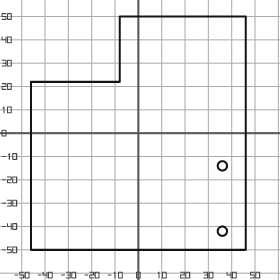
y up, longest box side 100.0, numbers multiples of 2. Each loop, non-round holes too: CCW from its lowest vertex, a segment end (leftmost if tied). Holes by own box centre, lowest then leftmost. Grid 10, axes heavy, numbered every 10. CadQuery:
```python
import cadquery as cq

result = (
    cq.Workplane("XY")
    .moveTo(-46.0, -50.0)
    .lineTo(46.0, -50.0)
    .lineTo(46.0, 50.0)
    .lineTo(-8.0, 50.0)
    .lineTo(-8.0, 22.0)
    .lineTo(-46.0, 22.0)
    .close()
    .moveTo(36.0, -42.0)
    .circle(2.0)
    .moveTo(36.0, -14.0)
    .circle(2.0)
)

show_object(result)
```